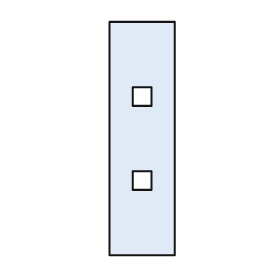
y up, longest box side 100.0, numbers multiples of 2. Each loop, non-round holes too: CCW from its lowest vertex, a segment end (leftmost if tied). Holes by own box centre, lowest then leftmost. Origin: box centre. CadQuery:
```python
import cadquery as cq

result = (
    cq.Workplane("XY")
    .moveTo(-14.0, -50.0)
    .lineTo(14.0, -50.0)
    .lineTo(14.0, 50.0)
    .lineTo(-14.0, 50.0)
    .close()
    .moveTo(-4.0, -22.0)
    .lineTo(4.0, -22.0)
    .lineTo(4.0, -14.0)
    .lineTo(-4.0, -14.0)
    .close()
    .moveTo(-4.0, 14.0)
    .lineTo(4.0, 14.0)
    .lineTo(4.0, 22.0)
    .lineTo(-4.0, 22.0)
    .close()
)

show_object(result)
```